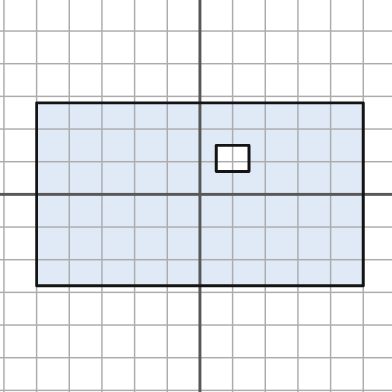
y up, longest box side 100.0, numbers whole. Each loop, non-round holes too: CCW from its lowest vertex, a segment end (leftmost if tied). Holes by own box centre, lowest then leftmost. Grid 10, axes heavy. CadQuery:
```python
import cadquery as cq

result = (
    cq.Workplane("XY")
    .moveTo(-50.0, -28.0)
    .lineTo(50.0, -28.0)
    .lineTo(50.0, 28.0)
    .lineTo(-50.0, 28.0)
    .close()
    .moveTo(5.0, 7.0)
    .lineTo(15.0, 7.0)
    .lineTo(15.0, 15.0)
    .lineTo(5.0, 15.0)
    .close()
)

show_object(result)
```